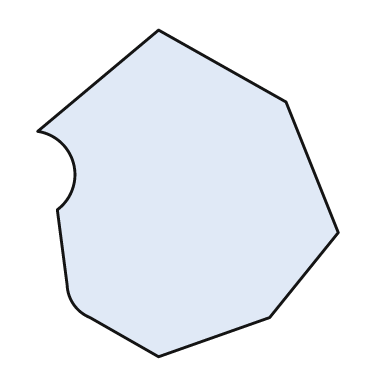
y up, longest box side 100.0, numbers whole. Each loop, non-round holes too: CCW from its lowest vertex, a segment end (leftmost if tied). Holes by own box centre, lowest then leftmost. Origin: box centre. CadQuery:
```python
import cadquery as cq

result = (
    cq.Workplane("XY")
    .moveTo(-9.0, -50.0)
    .lineTo(25.0, -38.0)
    .lineTo(46.0, -12.0)
    .lineTo(30.0, 28.0)
    .lineTo(-9.0, 50.0)
    .lineTo(-46.0, 19.0)
    .threePointArc((-35.0, 9.0), (-40.0, -5.0))
    .lineTo(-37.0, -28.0)
    .threePointArc((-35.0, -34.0), (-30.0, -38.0))
    .close()
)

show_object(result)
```